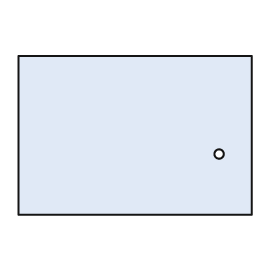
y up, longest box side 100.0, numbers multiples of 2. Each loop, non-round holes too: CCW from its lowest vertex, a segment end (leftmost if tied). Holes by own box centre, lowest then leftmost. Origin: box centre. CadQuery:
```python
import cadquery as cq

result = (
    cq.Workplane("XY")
    .moveTo(-50.0, -34.0)
    .lineTo(50.0, -34.0)
    .lineTo(50.0, 34.0)
    .lineTo(-50.0, 34.0)
    .close()
    .moveTo(36.0, -8.0)
    .circle(2.0)
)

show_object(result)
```